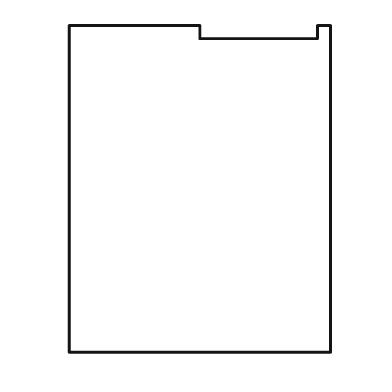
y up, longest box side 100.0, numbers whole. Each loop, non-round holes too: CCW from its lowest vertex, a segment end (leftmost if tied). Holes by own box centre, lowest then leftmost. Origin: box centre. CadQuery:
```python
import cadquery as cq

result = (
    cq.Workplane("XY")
    .moveTo(-40.0, -50.0)
    .lineTo(40.0, -50.0)
    .lineTo(40.0, 50.0)
    .lineTo(36.0, 50.0)
    .lineTo(36.0, 46.0)
    .lineTo(0.0, 46.0)
    .lineTo(0.0, 50.0)
    .lineTo(-40.0, 50.0)
    .close()
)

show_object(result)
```